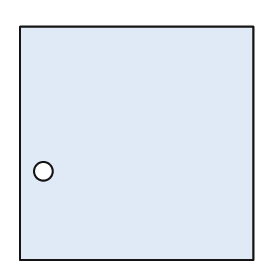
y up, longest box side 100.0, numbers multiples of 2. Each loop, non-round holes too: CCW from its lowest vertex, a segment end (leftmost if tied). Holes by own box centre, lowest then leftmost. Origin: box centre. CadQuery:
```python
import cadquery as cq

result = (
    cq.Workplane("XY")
    .moveTo(-50.0, -50.0)
    .lineTo(50.0, -50.0)
    .lineTo(50.0, 50.0)
    .lineTo(-50.0, 50.0)
    .close()
    .moveTo(-40.0, -12.0)
    .circle(4.0)
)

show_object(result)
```